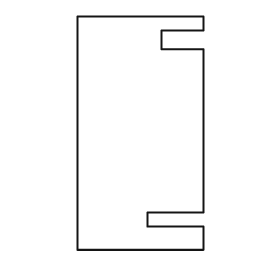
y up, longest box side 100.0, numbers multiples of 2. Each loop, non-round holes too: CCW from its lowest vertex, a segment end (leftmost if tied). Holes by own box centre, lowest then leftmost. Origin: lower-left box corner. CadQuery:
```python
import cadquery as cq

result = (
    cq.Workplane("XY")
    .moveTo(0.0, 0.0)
    .lineTo(54.0, 0.0)
    .lineTo(54.0, 10.0)
    .lineTo(30.0, 10.0)
    .lineTo(30.0, 16.0)
    .lineTo(54.0, 16.0)
    .lineTo(54.0, 86.0)
    .lineTo(36.0, 86.0)
    .lineTo(36.0, 94.0)
    .lineTo(54.0, 94.0)
    .lineTo(54.0, 100.0)
    .lineTo(0.0, 100.0)
    .close()
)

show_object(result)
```